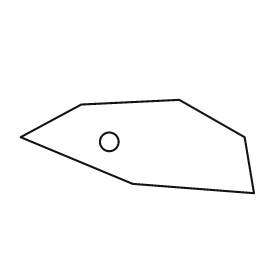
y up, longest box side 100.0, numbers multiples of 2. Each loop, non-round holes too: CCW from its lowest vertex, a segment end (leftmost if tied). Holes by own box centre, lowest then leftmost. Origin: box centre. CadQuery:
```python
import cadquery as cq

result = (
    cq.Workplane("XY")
    .moveTo(50.0, -20.0)
    .lineTo(46.0, 4.0)
    .lineTo(18.0, 20.0)
    .lineTo(-24.0, 18.0)
    .lineTo(-50.0, 4.0)
    .lineTo(-2.0, -16.0)
    .close()
    .moveTo(-12.0, 2.0)
    .circle(4.0)
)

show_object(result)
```